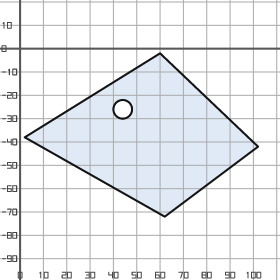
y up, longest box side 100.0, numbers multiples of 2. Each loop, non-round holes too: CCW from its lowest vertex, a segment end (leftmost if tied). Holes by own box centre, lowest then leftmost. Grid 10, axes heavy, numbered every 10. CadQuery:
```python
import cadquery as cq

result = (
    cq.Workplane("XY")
    .moveTo(62.0, -72.0)
    .lineTo(102.0, -42.0)
    .lineTo(60.0, -2.0)
    .lineTo(2.0, -38.0)
    .close()
    .moveTo(44.0, -26.0)
    .circle(4.0)
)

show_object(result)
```